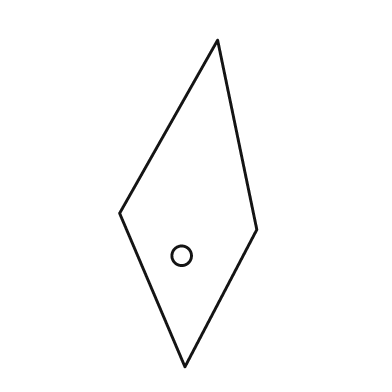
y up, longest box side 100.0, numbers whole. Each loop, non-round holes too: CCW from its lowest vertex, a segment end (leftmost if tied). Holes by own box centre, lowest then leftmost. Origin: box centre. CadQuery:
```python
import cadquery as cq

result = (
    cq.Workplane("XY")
    .moveTo(-1.0, -50.0)
    .lineTo(21.0, -8.0)
    .lineTo(9.0, 50.0)
    .lineTo(-21.0, -3.0)
    .close()
    .moveTo(-2.0, -16.0)
    .circle(3.0)
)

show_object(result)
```